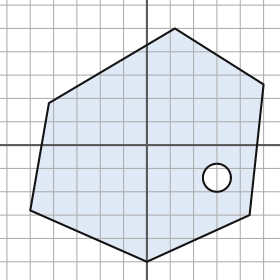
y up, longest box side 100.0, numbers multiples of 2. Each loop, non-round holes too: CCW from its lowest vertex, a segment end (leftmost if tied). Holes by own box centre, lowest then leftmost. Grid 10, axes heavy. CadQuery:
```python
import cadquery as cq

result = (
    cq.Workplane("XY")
    .moveTo(0.0, -50.0)
    .lineTo(44.0, -30.0)
    .lineTo(50.0, 26.0)
    .lineTo(12.0, 50.0)
    .lineTo(-42.0, 18.0)
    .lineTo(-50.0, -28.0)
    .close()
    .moveTo(30.0, -14.0)
    .circle(6.0)
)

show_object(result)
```